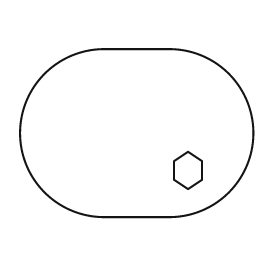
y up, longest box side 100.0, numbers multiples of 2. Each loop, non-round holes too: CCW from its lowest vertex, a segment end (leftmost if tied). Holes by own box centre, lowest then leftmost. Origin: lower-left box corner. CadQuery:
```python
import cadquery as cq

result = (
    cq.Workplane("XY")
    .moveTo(36.0, 0.0)
    .lineTo(64.0, 0.0)
    .threePointArc((100.0, 36.0), (64.0, 72.0))
    .lineTo(36.0, 72.0)
    .threePointArc((0.0, 36.0), (36.0, 0.0))
    .close()
    .moveTo(72.0, 12.0)
    .lineTo(78.0, 16.0)
    .lineTo(78.0, 24.0)
    .lineTo(72.0, 28.0)
    .lineTo(66.0, 24.0)
    .lineTo(66.0, 16.0)
    .close()
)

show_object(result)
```